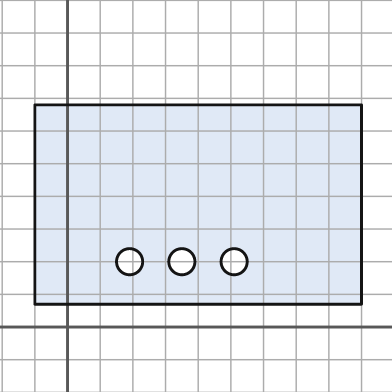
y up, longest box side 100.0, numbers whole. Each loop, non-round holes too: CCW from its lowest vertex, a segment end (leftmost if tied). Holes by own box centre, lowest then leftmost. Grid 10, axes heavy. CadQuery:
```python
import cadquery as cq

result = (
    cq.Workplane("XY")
    .moveTo(-10.0, 7.0)
    .lineTo(90.0, 7.0)
    .lineTo(90.0, 68.0)
    .lineTo(-10.0, 68.0)
    .close()
    .moveTo(19.0, 20.0)
    .circle(4.0)
    .moveTo(35.0, 20.0)
    .circle(4.0)
    .moveTo(51.0, 20.0)
    .circle(4.0)
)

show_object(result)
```